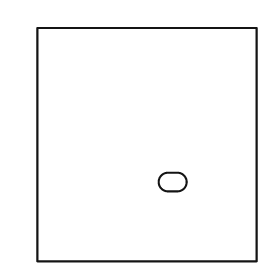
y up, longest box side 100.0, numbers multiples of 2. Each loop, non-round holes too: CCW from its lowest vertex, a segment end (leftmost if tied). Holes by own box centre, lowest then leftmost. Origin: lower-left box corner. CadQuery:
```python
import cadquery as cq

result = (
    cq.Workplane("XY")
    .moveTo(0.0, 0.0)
    .lineTo(94.0, 0.0)
    .lineTo(94.0, 100.0)
    .lineTo(0.0, 100.0)
    .close()
    .moveTo(56.0, 30.0)
    .lineTo(60.0, 30.0)
    .threePointArc((64.0, 34.0), (60.0, 38.0))
    .lineTo(56.0, 38.0)
    .threePointArc((52.0, 34.0), (56.0, 30.0))
    .close()
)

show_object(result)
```